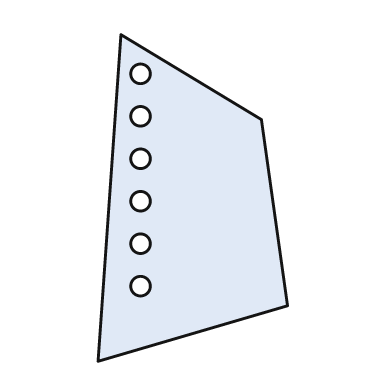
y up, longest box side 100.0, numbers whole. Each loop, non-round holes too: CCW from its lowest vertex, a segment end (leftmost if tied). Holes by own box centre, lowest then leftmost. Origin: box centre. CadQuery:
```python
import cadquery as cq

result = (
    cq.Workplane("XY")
    .moveTo(-29.0, -50.0)
    .lineTo(29.0, -33.0)
    .lineTo(21.0, 24.0)
    .lineTo(-22.0, 50.0)
    .close()
    .moveTo(-16.0, -27.0)
    .circle(3.0)
    .moveTo(-16.0, -14.0)
    .circle(3.0)
    .moveTo(-16.0, -1.0)
    .circle(3.0)
    .moveTo(-16.0, 12.0)
    .circle(3.0)
    .moveTo(-16.0, 25.0)
    .circle(3.0)
    .moveTo(-16.0, 38.0)
    .circle(3.0)
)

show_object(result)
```